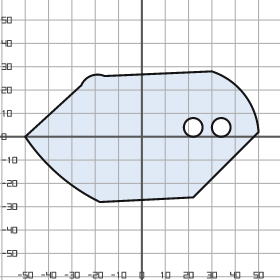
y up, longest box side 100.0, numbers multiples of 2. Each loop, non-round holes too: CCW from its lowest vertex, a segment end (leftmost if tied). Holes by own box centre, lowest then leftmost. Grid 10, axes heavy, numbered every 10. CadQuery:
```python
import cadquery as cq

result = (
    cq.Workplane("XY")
    .moveTo(-18.0, -28.0)
    .lineTo(22.0, -26.0)
    .lineTo(50.0, 2.0)
    .threePointArc((44.0, 18.0), (30.0, 28.0))
    .lineTo(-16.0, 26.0)
    .threePointArc((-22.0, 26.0), (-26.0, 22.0))
    .lineTo(-50.0, 0.0)
    .threePointArc((-36.0, -16.0), (-18.0, -28.0))
    .close()
    .moveTo(22.0, 4.0)
    .circle(4.0)
    .moveTo(34.0, 4.0)
    .circle(4.0)
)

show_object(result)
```